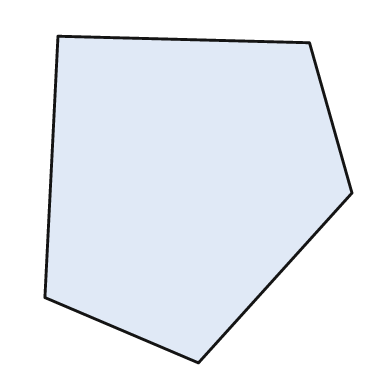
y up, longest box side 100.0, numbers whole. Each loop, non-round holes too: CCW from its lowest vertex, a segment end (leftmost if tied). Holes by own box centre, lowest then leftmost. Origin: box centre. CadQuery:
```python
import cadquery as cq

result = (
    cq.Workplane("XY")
    .moveTo(0.0, -50.0)
    .lineTo(47.0, 2.0)
    .lineTo(34.0, 48.0)
    .lineTo(-43.0, 50.0)
    .lineTo(-47.0, -30.0)
    .close()
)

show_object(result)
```